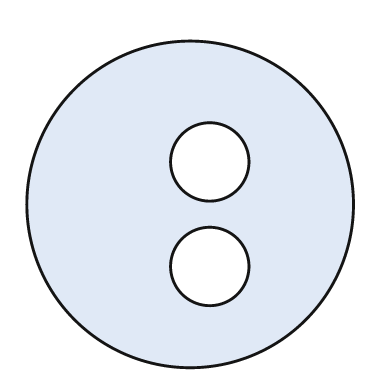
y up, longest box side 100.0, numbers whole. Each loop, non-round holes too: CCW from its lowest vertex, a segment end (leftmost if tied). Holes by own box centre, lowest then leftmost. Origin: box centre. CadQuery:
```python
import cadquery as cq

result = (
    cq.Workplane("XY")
    .moveTo(0.0, 0.0)
    .circle(50.0)
    .moveTo(6.0, -19.0)
    .circle(12.0)
    .moveTo(6.0, 13.0)
    .circle(12.0)
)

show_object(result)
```